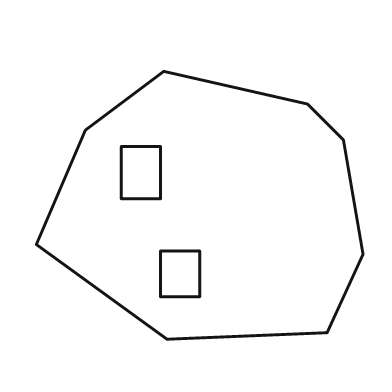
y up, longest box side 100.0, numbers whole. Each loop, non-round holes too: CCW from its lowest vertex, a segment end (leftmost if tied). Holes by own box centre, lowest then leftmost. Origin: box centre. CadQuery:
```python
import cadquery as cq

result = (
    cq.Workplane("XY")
    .moveTo(-10.0, -41.0)
    .lineTo(39.0, -39.0)
    .lineTo(50.0, -15.0)
    .lineTo(44.0, 20.0)
    .lineTo(33.0, 31.0)
    .lineTo(-11.0, 41.0)
    .lineTo(-35.0, 23.0)
    .lineTo(-50.0, -12.0)
    .close()
    .moveTo(-12.0, -28.0)
    .lineTo(0.0, -28.0)
    .lineTo(0.0, -14.0)
    .lineTo(-12.0, -14.0)
    .close()
    .moveTo(-24.0, 2.0)
    .lineTo(-12.0, 2.0)
    .lineTo(-12.0, 18.0)
    .lineTo(-24.0, 18.0)
    .close()
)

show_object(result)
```